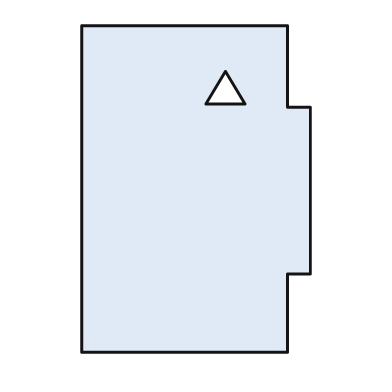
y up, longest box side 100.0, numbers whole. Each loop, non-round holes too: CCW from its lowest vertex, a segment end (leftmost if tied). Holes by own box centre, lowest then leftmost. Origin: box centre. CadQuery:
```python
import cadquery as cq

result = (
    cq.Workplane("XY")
    .moveTo(-35.0, -50.0)
    .lineTo(28.0, -50.0)
    .lineTo(28.0, -26.0)
    .lineTo(35.0, -26.0)
    .lineTo(35.0, 25.0)
    .lineTo(28.0, 25.0)
    .lineTo(28.0, 50.0)
    .lineTo(-35.0, 50.0)
    .close()
    .moveTo(3.0, 26.0)
    .lineTo(15.0, 26.0)
    .lineTo(9.0, 36.0)
    .close()
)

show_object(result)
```